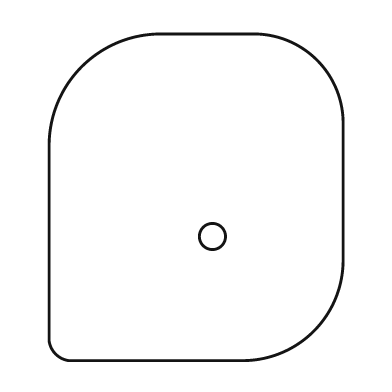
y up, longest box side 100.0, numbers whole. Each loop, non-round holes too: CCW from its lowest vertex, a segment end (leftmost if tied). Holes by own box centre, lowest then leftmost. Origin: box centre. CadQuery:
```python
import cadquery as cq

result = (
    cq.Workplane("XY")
    .moveTo(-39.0, -50.0)
    .lineTo(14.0, -50.0)
    .threePointArc((36.0, -41.0), (45.0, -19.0))
    .lineTo(45.0, 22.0)
    .threePointArc((37.0, 42.0), (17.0, 50.0))
    .lineTo(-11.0, 50.0)
    .threePointArc((-35.0, 40.0), (-45.0, 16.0))
    .lineTo(-45.0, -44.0)
    .threePointArc((-43.0, -48.0), (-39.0, -50.0))
    .close()
    .moveTo(5.0, -12.0)
    .circle(4.0)
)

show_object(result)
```